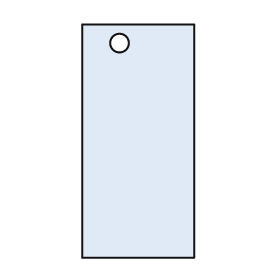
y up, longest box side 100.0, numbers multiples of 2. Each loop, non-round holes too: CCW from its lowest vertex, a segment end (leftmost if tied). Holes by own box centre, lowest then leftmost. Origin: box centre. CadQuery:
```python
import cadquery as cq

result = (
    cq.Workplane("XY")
    .moveTo(-24.0, -50.0)
    .lineTo(24.0, -50.0)
    .lineTo(24.0, 50.0)
    .lineTo(-24.0, 50.0)
    .close()
    .moveTo(-8.0, 42.0)
    .circle(4.0)
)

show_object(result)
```